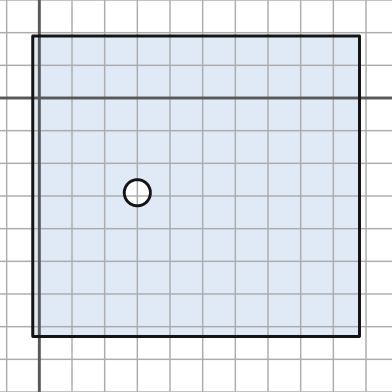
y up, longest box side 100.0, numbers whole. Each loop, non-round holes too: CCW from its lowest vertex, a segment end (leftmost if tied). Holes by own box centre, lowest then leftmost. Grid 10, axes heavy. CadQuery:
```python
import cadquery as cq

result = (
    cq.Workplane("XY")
    .moveTo(-2.0, -73.0)
    .lineTo(98.0, -73.0)
    .lineTo(98.0, 19.0)
    .lineTo(-2.0, 19.0)
    .close()
    .moveTo(30.0, -29.0)
    .circle(4.0)
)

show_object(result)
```